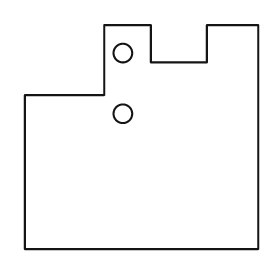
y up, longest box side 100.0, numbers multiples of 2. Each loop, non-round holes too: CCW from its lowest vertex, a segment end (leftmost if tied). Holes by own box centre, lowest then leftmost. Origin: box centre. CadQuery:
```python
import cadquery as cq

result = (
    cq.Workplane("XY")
    .moveTo(-50.0, -48.0)
    .lineTo(50.0, -48.0)
    .lineTo(50.0, 48.0)
    .lineTo(28.0, 48.0)
    .lineTo(28.0, 32.0)
    .lineTo(4.0, 32.0)
    .lineTo(4.0, 48.0)
    .lineTo(-16.0, 48.0)
    .lineTo(-16.0, 18.0)
    .lineTo(-50.0, 18.0)
    .close()
    .moveTo(-8.0, 10.0)
    .circle(4.0)
    .moveTo(-8.0, 36.0)
    .circle(4.0)
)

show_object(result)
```